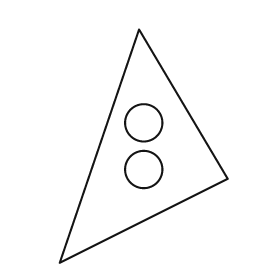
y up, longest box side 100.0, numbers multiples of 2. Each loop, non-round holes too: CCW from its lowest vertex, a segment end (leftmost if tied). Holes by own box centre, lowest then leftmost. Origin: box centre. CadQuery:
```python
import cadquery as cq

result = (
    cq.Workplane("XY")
    .moveTo(-36.0, -50.0)
    .lineTo(36.0, -14.0)
    .lineTo(-2.0, 50.0)
    .close()
    .moveTo(0.0, -10.0)
    .circle(8.0)
    .moveTo(0.0, 10.0)
    .circle(8.0)
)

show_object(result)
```